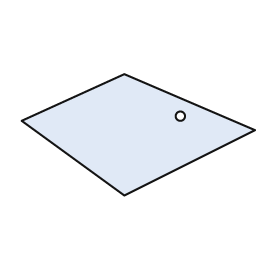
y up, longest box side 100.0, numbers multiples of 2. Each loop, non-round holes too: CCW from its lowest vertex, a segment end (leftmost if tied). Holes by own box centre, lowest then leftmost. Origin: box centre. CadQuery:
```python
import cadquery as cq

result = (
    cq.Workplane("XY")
    .moveTo(-6.0, -26.0)
    .lineTo(50.0, 2.0)
    .lineTo(-6.0, 26.0)
    .lineTo(-50.0, 6.0)
    .close()
    .moveTo(18.0, 8.0)
    .circle(2.0)
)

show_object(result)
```